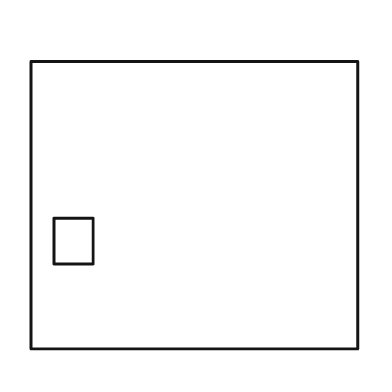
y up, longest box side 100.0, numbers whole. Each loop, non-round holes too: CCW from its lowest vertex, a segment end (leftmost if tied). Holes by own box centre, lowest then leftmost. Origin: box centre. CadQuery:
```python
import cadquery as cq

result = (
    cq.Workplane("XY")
    .moveTo(-50.0, -44.0)
    .lineTo(50.0, -44.0)
    .lineTo(50.0, 44.0)
    .lineTo(-50.0, 44.0)
    .close()
    .moveTo(-43.0, -18.0)
    .lineTo(-31.0, -18.0)
    .lineTo(-31.0, -4.0)
    .lineTo(-43.0, -4.0)
    .close()
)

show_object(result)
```